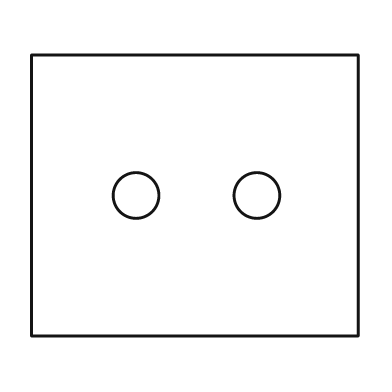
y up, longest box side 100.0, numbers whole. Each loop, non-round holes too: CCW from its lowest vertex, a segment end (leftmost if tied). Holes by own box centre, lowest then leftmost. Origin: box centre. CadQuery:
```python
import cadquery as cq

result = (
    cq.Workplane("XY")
    .moveTo(-50.0, -43.0)
    .lineTo(50.0, -43.0)
    .lineTo(50.0, 43.0)
    .lineTo(-50.0, 43.0)
    .close()
    .moveTo(-18.0, 0.0)
    .circle(7.0)
    .moveTo(19.0, 0.0)
    .circle(7.0)
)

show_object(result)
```